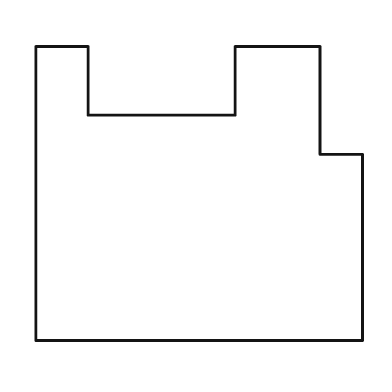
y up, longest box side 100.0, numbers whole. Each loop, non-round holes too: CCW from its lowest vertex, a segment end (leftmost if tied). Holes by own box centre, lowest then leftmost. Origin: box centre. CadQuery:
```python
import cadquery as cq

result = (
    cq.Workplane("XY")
    .moveTo(-50.0, -45.0)
    .lineTo(50.0, -45.0)
    .lineTo(50.0, 12.0)
    .lineTo(37.0, 12.0)
    .lineTo(37.0, 45.0)
    .lineTo(11.0, 45.0)
    .lineTo(11.0, 24.0)
    .lineTo(-34.0, 24.0)
    .lineTo(-34.0, 45.0)
    .lineTo(-50.0, 45.0)
    .close()
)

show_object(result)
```